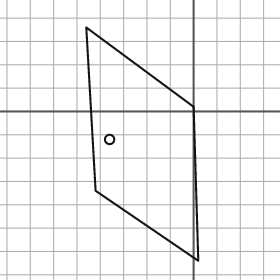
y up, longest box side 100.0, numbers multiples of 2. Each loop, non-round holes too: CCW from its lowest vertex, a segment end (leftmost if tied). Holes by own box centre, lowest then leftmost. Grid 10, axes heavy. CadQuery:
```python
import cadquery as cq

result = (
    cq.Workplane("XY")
    .moveTo(2.0, -64.0)
    .lineTo(0.0, 2.0)
    .lineTo(-46.0, 36.0)
    .lineTo(-42.0, -34.0)
    .close()
    .moveTo(-36.0, -12.0)
    .circle(2.0)
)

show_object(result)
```